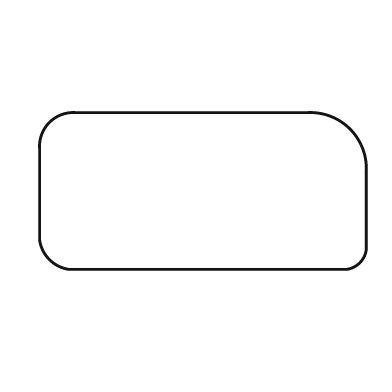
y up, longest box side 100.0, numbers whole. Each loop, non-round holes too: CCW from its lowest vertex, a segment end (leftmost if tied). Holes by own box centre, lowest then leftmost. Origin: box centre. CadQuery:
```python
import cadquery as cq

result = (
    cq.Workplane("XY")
    .moveTo(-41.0, -24.0)
    .lineTo(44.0, -24.0)
    .threePointArc((48.0, -22.0), (50.0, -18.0))
    .lineTo(50.0, 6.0)
    .threePointArc((45.0, 19.0), (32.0, 24.0))
    .lineTo(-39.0, 24.0)
    .threePointArc((-47.0, 21.0), (-50.0, 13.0))
    .lineTo(-50.0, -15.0)
    .threePointArc((-47.0, -21.0), (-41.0, -24.0))
    .close()
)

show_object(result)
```